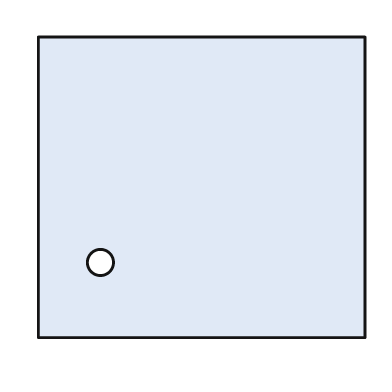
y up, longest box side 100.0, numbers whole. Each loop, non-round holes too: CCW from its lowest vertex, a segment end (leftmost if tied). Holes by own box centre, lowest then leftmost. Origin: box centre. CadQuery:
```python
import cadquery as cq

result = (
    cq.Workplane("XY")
    .moveTo(-50.0, -46.0)
    .lineTo(50.0, -46.0)
    .lineTo(50.0, 46.0)
    .lineTo(-50.0, 46.0)
    .close()
    .moveTo(-31.0, -23.0)
    .circle(4.0)
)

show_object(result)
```